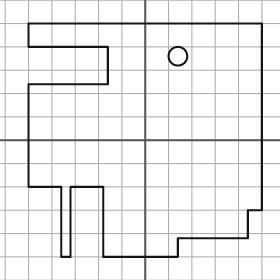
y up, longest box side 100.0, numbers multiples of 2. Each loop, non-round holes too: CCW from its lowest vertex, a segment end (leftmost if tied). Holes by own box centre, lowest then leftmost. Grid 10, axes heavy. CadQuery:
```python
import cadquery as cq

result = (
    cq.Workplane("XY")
    .moveTo(-36.0, -50.0)
    .lineTo(-32.0, -50.0)
    .lineTo(-32.0, -20.0)
    .lineTo(-18.0, -20.0)
    .lineTo(-18.0, -50.0)
    .lineTo(14.0, -50.0)
    .lineTo(14.0, -42.0)
    .lineTo(44.0, -42.0)
    .lineTo(44.0, -30.0)
    .lineTo(50.0, -30.0)
    .lineTo(50.0, 50.0)
    .lineTo(-50.0, 50.0)
    .lineTo(-50.0, 40.0)
    .lineTo(-16.0, 40.0)
    .lineTo(-16.0, 24.0)
    .lineTo(-50.0, 24.0)
    .lineTo(-50.0, -20.0)
    .lineTo(-36.0, -20.0)
    .close()
    .moveTo(14.0, 36.0)
    .circle(4.0)
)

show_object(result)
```